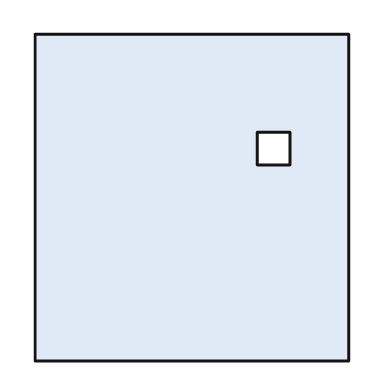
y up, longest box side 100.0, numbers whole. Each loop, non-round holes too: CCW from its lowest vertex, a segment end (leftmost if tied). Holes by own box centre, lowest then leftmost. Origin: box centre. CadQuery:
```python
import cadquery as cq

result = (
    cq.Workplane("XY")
    .moveTo(-48.0, -50.0)
    .lineTo(48.0, -50.0)
    .lineTo(48.0, 50.0)
    .lineTo(-48.0, 50.0)
    .close()
    .moveTo(20.0, 10.0)
    .lineTo(30.0, 10.0)
    .lineTo(30.0, 20.0)
    .lineTo(20.0, 20.0)
    .close()
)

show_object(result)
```